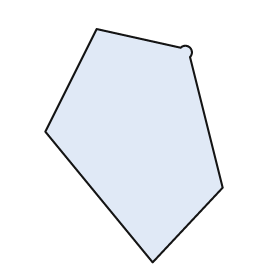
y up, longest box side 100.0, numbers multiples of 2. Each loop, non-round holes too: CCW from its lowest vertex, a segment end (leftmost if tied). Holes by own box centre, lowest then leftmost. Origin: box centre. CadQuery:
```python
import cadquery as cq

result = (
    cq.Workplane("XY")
    .moveTo(8.0, -50.0)
    .lineTo(38.0, -18.0)
    .lineTo(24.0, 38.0)
    .threePointArc((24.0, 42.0), (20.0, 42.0))
    .lineTo(-16.0, 50.0)
    .lineTo(-38.0, 6.0)
    .close()
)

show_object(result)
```